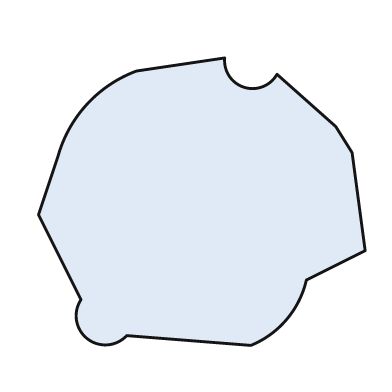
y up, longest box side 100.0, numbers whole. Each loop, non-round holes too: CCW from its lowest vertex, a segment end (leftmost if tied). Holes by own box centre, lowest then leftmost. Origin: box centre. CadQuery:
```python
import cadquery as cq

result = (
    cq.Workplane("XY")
    .moveTo(15.0, -44.0)
    .threePointArc((26.0, -36.0), (32.0, -24.0))
    .lineTo(50.0, -15.0)
    .lineTo(46.0, 15.0)
    .lineTo(41.0, 23.0)
    .lineTo(23.0, 39.0)
    .threePointArc((13.0, 35.0), (7.0, 44.0))
    .lineTo(-20.0, 40.0)
    .threePointArc((-35.0, 30.0), (-44.0, 14.0))
    .lineTo(-50.0, -4.0)
    .lineTo(-37.0, -30.0)
    .threePointArc((-35.0, -42.0), (-23.0, -41.0))
    .close()
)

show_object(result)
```